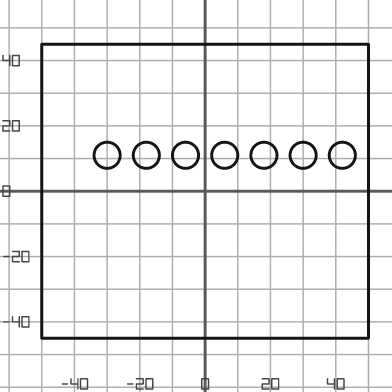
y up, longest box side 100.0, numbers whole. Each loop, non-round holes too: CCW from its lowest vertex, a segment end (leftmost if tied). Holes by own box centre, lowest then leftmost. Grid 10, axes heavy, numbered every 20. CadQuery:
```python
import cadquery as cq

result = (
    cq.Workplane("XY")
    .moveTo(-50.0, -45.0)
    .lineTo(50.0, -45.0)
    .lineTo(50.0, 45.0)
    .lineTo(-50.0, 45.0)
    .close()
    .moveTo(-30.0, 11.0)
    .circle(4.0)
    .moveTo(-18.0, 11.0)
    .circle(4.0)
    .moveTo(-6.0, 11.0)
    .circle(4.0)
    .moveTo(6.0, 11.0)
    .circle(4.0)
    .moveTo(18.0, 11.0)
    .circle(4.0)
    .moveTo(30.0, 11.0)
    .circle(4.0)
    .moveTo(42.0, 11.0)
    .circle(4.0)
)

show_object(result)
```